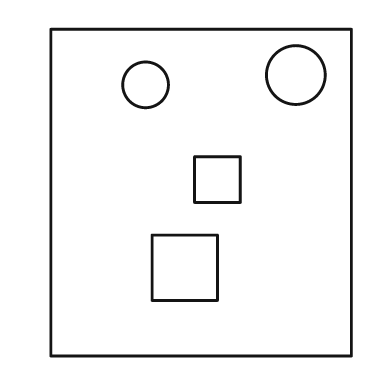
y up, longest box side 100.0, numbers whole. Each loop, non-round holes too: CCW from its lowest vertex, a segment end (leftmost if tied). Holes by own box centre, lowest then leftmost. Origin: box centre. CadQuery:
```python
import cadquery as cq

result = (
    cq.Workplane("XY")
    .moveTo(-46.0, -50.0)
    .lineTo(46.0, -50.0)
    .lineTo(46.0, 50.0)
    .lineTo(-46.0, 50.0)
    .close()
    .moveTo(-15.0, -33.0)
    .lineTo(5.0, -33.0)
    .lineTo(5.0, -13.0)
    .lineTo(-15.0, -13.0)
    .close()
    .moveTo(-2.0, -3.0)
    .lineTo(12.0, -3.0)
    .lineTo(12.0, 11.0)
    .lineTo(-2.0, 11.0)
    .close()
    .moveTo(-17.0, 33.0)
    .circle(7.0)
    .moveTo(29.0, 36.0)
    .circle(9.0)
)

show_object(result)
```